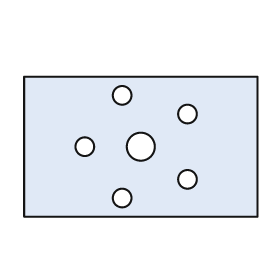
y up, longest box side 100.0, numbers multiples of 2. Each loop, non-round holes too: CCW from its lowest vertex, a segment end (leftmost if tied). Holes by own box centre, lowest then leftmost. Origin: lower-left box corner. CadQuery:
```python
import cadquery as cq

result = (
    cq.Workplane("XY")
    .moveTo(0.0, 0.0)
    .lineTo(100.0, 0.0)
    .lineTo(100.0, 60.0)
    .lineTo(0.0, 60.0)
    .close()
    .moveTo(42.0, 8.0)
    .circle(4.0)
    .moveTo(70.0, 16.0)
    .circle(4.0)
    .moveTo(26.0, 30.0)
    .circle(4.0)
    .moveTo(50.0, 30.0)
    .circle(6.0)
    .moveTo(70.0, 44.0)
    .circle(4.0)
    .moveTo(42.0, 52.0)
    .circle(4.0)
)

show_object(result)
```